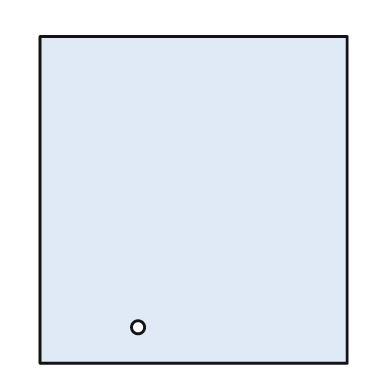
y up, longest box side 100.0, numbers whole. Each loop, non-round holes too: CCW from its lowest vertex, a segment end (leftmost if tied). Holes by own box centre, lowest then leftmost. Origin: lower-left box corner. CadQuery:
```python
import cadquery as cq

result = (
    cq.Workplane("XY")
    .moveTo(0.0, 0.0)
    .lineTo(94.0, 0.0)
    .lineTo(94.0, 100.0)
    .lineTo(0.0, 100.0)
    .close()
    .moveTo(30.0, 11.0)
    .circle(2.0)
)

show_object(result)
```